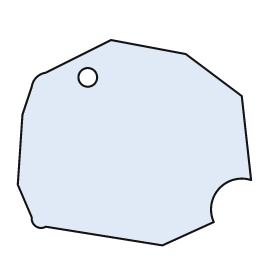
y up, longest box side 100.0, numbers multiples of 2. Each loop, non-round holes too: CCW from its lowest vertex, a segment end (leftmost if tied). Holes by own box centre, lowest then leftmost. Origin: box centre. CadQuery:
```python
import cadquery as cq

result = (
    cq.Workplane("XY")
    .moveTo(12.0, -44.0)
    .lineTo(34.0, -34.0)
    .threePointArc((36.0, -20.0), (50.0, -16.0))
    .lineTo(46.0, 20.0)
    .lineTo(22.0, 38.0)
    .lineTo(-10.0, 44.0)
    .lineTo(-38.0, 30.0)
    .threePointArc((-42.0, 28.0), (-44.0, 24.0))
    .lineTo(-48.0, 12.0)
    .lineTo(-50.0, -18.0)
    .lineTo(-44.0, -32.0)
    .threePointArc((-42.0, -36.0), (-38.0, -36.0))
    .close()
    .moveTo(-20.0, 28.0)
    .circle(4.0)
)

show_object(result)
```